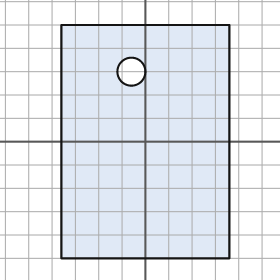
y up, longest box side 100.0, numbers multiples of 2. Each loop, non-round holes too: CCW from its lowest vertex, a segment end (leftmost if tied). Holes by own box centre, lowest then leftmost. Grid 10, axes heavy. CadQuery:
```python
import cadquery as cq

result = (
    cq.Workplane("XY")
    .moveTo(-36.0, -50.0)
    .lineTo(36.0, -50.0)
    .lineTo(36.0, 50.0)
    .lineTo(-36.0, 50.0)
    .close()
    .moveTo(-6.0, 30.0)
    .circle(6.0)
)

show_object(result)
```